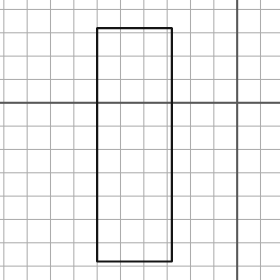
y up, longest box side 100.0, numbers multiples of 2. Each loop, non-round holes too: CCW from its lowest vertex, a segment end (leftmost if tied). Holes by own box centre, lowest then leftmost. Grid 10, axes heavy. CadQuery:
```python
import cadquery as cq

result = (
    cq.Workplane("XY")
    .moveTo(-60.0, -68.0)
    .lineTo(-28.0, -68.0)
    .lineTo(-28.0, 32.0)
    .lineTo(-60.0, 32.0)
    .close()
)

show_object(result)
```